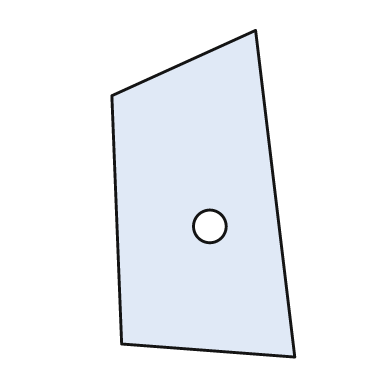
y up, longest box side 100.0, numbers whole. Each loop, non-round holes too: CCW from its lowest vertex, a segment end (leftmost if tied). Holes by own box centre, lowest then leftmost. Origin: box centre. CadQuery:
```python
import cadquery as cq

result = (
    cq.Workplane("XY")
    .moveTo(28.0, -50.0)
    .lineTo(16.0, 50.0)
    .lineTo(-28.0, 30.0)
    .lineTo(-25.0, -46.0)
    .close()
    .moveTo(2.0, -10.0)
    .circle(5.0)
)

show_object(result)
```